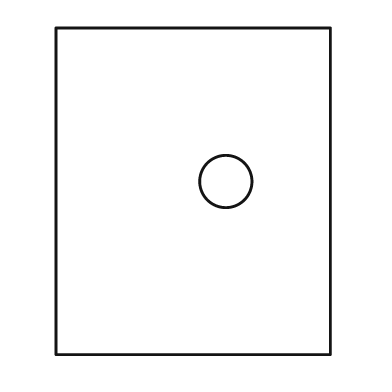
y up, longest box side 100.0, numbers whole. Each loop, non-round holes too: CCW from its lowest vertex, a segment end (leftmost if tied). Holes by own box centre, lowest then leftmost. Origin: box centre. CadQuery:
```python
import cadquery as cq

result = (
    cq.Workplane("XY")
    .moveTo(-42.0, -50.0)
    .lineTo(42.0, -50.0)
    .lineTo(42.0, 50.0)
    .lineTo(-42.0, 50.0)
    .close()
    .moveTo(10.0, 3.0)
    .circle(8.0)
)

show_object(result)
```